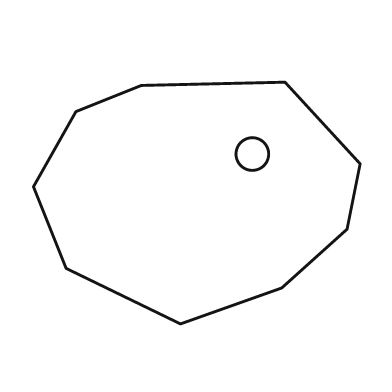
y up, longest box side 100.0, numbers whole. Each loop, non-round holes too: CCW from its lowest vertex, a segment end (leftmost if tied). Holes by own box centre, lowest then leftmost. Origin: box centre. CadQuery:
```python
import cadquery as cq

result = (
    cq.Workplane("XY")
    .moveTo(-5.0, -37.0)
    .lineTo(26.0, -26.0)
    .lineTo(46.0, -8.0)
    .lineTo(50.0, 12.0)
    .lineTo(27.0, 37.0)
    .lineTo(-17.0, 36.0)
    .lineTo(-37.0, 28.0)
    .lineTo(-50.0, 5.0)
    .lineTo(-40.0, -20.0)
    .close()
    .moveTo(17.0, 15.0)
    .circle(5.0)
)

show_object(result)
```